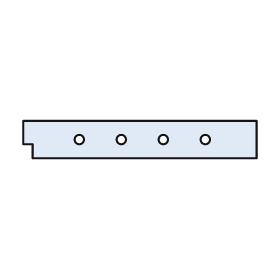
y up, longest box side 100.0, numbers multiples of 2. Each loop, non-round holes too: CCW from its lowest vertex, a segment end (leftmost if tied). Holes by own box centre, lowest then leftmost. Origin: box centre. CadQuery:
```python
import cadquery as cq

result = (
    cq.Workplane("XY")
    .moveTo(-46.0, -8.0)
    .lineTo(50.0, -8.0)
    .lineTo(50.0, 8.0)
    .lineTo(-50.0, 8.0)
    .lineTo(-50.0, -2.0)
    .lineTo(-46.0, -2.0)
    .close()
    .moveTo(-26.0, 0.0)
    .circle(2.0)
    .moveTo(-8.0, 0.0)
    .circle(2.0)
    .moveTo(10.0, 0.0)
    .circle(2.0)
    .moveTo(28.0, 0.0)
    .circle(2.0)
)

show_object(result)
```